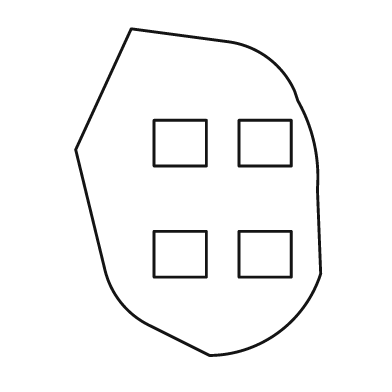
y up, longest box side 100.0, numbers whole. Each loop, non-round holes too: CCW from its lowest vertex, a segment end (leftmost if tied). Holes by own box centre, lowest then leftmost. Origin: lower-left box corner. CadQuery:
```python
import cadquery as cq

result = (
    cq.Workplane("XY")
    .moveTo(41.0, 0.0)
    .threePointArc((62.0, 7.0), (75.0, 25.0))
    .lineTo(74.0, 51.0)
    .threePointArc((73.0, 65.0), (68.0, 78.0))
    .lineTo(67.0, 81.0)
    .threePointArc((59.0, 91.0), (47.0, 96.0))
    .lineTo(17.0, 100.0)
    .lineTo(0.0, 63.0)
    .lineTo(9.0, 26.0)
    .threePointArc((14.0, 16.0), (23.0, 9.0))
    .close()
    .moveTo(24.0, 24.0)
    .lineTo(40.0, 24.0)
    .lineTo(40.0, 38.0)
    .lineTo(24.0, 38.0)
    .close()
    .moveTo(50.0, 24.0)
    .lineTo(66.0, 24.0)
    .lineTo(66.0, 38.0)
    .lineTo(50.0, 38.0)
    .close()
    .moveTo(24.0, 58.0)
    .lineTo(40.0, 58.0)
    .lineTo(40.0, 72.0)
    .lineTo(24.0, 72.0)
    .close()
    .moveTo(50.0, 58.0)
    .lineTo(66.0, 58.0)
    .lineTo(66.0, 72.0)
    .lineTo(50.0, 72.0)
    .close()
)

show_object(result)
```